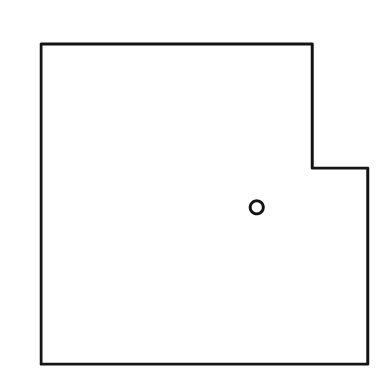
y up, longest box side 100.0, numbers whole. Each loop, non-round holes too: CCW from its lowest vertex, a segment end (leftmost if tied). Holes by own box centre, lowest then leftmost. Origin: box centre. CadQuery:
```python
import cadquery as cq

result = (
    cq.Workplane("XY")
    .moveTo(-50.0, -49.0)
    .lineTo(50.0, -49.0)
    .lineTo(50.0, 11.0)
    .lineTo(33.0, 11.0)
    .lineTo(33.0, 49.0)
    .lineTo(-50.0, 49.0)
    .close()
    .moveTo(16.0, -1.0)
    .circle(2.0)
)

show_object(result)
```